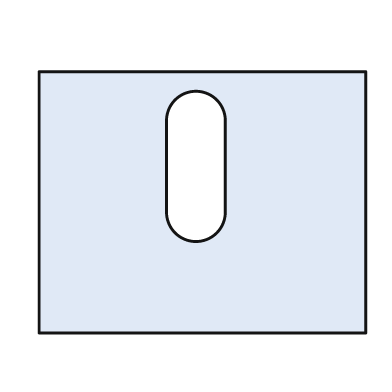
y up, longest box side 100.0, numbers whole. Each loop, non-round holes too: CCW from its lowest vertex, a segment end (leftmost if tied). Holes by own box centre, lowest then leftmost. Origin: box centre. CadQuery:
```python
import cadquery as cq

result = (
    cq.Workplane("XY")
    .moveTo(-50.0, -40.0)
    .lineTo(50.0, -40.0)
    .lineTo(50.0, 40.0)
    .lineTo(-50.0, 40.0)
    .close()
    .moveTo(-11.0, -3.0)
    .threePointArc((-2.0, -12.0), (7.0, -3.0))
    .lineTo(7.0, 25.0)
    .threePointArc((-2.0, 34.0), (-11.0, 25.0))
    .close()
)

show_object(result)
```